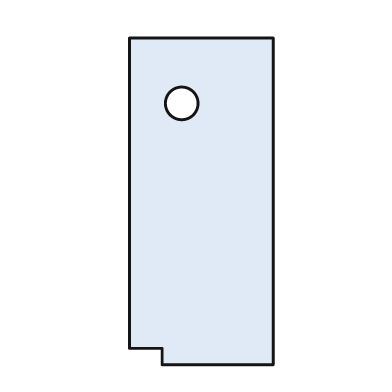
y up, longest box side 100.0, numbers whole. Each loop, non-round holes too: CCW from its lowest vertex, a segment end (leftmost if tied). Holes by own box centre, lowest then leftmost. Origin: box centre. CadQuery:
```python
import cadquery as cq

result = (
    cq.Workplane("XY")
    .moveTo(-12.0, -50.0)
    .lineTo(22.0, -50.0)
    .lineTo(22.0, 50.0)
    .lineTo(-22.0, 50.0)
    .lineTo(-22.0, -45.0)
    .lineTo(-12.0, -45.0)
    .close()
    .moveTo(-6.0, 30.0)
    .circle(5.0)
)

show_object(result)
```